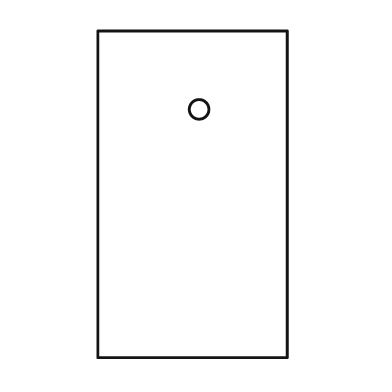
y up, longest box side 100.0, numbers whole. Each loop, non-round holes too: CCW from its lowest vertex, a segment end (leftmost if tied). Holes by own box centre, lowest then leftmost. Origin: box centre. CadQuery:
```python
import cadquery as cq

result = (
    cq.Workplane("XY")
    .moveTo(-29.0, -50.0)
    .lineTo(29.0, -50.0)
    .lineTo(29.0, 50.0)
    .lineTo(-29.0, 50.0)
    .close()
    .moveTo(2.0, 26.0)
    .circle(3.0)
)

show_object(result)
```